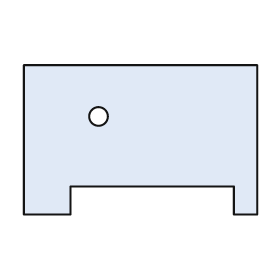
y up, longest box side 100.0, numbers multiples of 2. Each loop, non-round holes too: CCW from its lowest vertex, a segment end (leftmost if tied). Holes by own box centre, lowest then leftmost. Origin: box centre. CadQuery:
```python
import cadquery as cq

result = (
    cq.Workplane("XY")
    .moveTo(-50.0, -32.0)
    .lineTo(-30.0, -32.0)
    .lineTo(-30.0, -20.0)
    .lineTo(40.0, -20.0)
    .lineTo(40.0, -32.0)
    .lineTo(50.0, -32.0)
    .lineTo(50.0, 32.0)
    .lineTo(-50.0, 32.0)
    .close()
    .moveTo(-18.0, 10.0)
    .circle(4.0)
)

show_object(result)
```